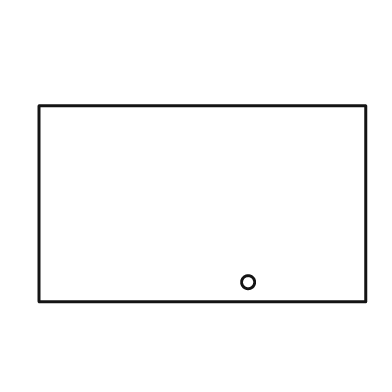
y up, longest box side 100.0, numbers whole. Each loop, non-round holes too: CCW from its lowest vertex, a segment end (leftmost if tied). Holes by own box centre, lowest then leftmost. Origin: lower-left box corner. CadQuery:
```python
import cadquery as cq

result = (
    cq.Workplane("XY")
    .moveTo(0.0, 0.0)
    .lineTo(100.0, 0.0)
    .lineTo(100.0, 60.0)
    .lineTo(0.0, 60.0)
    .close()
    .moveTo(64.0, 6.0)
    .circle(2.0)
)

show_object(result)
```